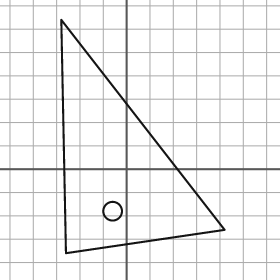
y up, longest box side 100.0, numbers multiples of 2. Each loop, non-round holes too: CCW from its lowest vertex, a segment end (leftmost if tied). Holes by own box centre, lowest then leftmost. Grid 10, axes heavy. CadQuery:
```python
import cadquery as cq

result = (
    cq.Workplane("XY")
    .moveTo(-26.0, -36.0)
    .lineTo(42.0, -26.0)
    .lineTo(-28.0, 64.0)
    .close()
    .moveTo(-6.0, -18.0)
    .circle(4.0)
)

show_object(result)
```